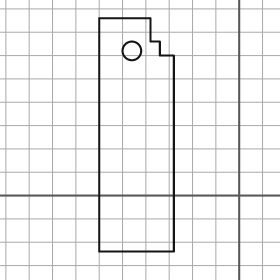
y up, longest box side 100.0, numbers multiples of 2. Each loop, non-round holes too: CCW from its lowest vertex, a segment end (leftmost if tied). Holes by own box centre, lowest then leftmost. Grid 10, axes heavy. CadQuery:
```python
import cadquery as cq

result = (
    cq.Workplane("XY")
    .moveTo(-60.0, -24.0)
    .lineTo(-28.0, -24.0)
    .lineTo(-28.0, 60.0)
    .lineTo(-34.0, 60.0)
    .lineTo(-34.0, 66.0)
    .lineTo(-38.0, 66.0)
    .lineTo(-38.0, 76.0)
    .lineTo(-60.0, 76.0)
    .close()
    .moveTo(-46.0, 62.0)
    .circle(4.0)
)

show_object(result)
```